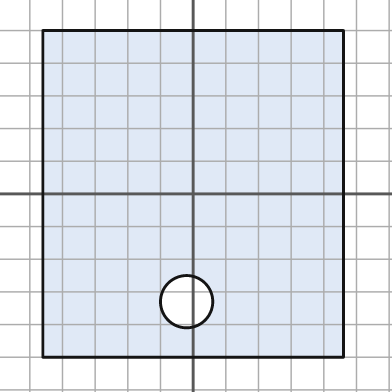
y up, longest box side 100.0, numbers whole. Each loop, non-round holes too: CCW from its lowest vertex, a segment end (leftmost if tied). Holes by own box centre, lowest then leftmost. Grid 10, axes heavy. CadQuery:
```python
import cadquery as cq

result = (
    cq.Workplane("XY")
    .moveTo(-46.0, -50.0)
    .lineTo(46.0, -50.0)
    .lineTo(46.0, 50.0)
    .lineTo(-46.0, 50.0)
    .close()
    .moveTo(-2.0, -33.0)
    .circle(8.0)
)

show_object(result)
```